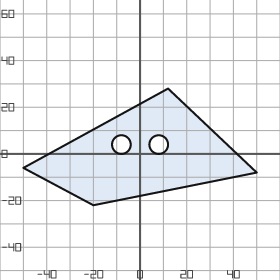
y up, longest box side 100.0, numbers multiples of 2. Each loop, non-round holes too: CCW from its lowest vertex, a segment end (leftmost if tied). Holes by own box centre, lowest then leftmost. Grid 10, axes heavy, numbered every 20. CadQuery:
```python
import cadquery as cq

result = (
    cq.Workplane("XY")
    .moveTo(-20.0, -22.0)
    .lineTo(50.0, -8.0)
    .lineTo(12.0, 28.0)
    .lineTo(-50.0, -6.0)
    .close()
    .moveTo(-8.0, 4.0)
    .circle(4.0)
    .moveTo(8.0, 4.0)
    .circle(4.0)
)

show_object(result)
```